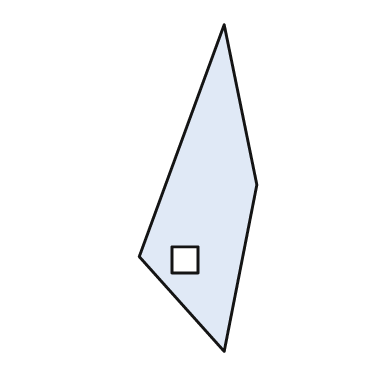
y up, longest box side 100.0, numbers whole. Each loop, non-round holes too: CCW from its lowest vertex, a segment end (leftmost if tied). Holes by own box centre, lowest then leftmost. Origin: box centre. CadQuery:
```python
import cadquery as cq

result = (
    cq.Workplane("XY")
    .moveTo(8.0, -50.0)
    .lineTo(18.0, 1.0)
    .lineTo(8.0, 50.0)
    .lineTo(-18.0, -21.0)
    .close()
    .moveTo(-8.0, -26.0)
    .lineTo(0.0, -26.0)
    .lineTo(0.0, -18.0)
    .lineTo(-8.0, -18.0)
    .close()
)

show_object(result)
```